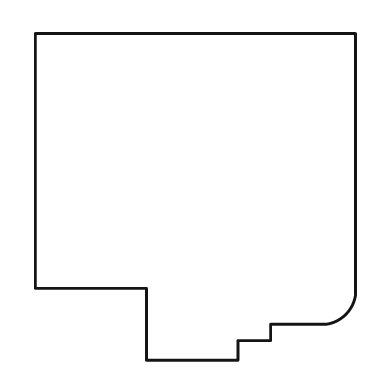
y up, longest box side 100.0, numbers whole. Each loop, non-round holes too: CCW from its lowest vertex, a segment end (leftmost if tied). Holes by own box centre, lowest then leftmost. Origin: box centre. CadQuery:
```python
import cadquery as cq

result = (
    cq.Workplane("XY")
    .moveTo(-15.0, -50.0)
    .lineTo(13.0, -50.0)
    .lineTo(13.0, -44.0)
    .lineTo(23.0, -44.0)
    .lineTo(23.0, -39.0)
    .lineTo(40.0, -39.0)
    .threePointArc((46.0, -36.0), (49.0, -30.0))
    .lineTo(49.0, 50.0)
    .lineTo(-49.0, 50.0)
    .lineTo(-49.0, -28.0)
    .lineTo(-15.0, -28.0)
    .close()
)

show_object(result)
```